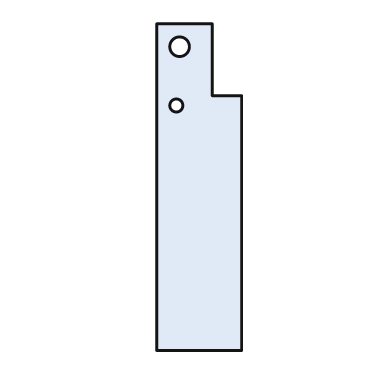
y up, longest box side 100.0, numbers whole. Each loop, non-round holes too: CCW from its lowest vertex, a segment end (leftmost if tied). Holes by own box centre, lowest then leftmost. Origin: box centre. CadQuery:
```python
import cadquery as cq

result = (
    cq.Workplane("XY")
    .moveTo(-13.0, -50.0)
    .lineTo(13.0, -50.0)
    .lineTo(13.0, 28.0)
    .lineTo(4.0, 28.0)
    .lineTo(4.0, 50.0)
    .lineTo(-13.0, 50.0)
    .close()
    .moveTo(-7.0, 25.0)
    .circle(2.0)
    .moveTo(-6.0, 43.0)
    .circle(3.0)
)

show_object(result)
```